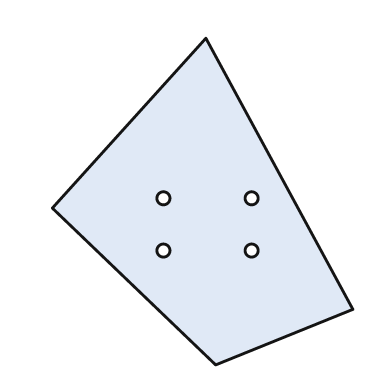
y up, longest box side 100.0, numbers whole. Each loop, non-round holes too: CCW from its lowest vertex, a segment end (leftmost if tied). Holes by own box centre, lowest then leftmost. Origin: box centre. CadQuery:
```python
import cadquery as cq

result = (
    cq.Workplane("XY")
    .moveTo(4.0, -50.0)
    .lineTo(46.0, -33.0)
    .lineTo(1.0, 50.0)
    .lineTo(-46.0, -2.0)
    .close()
    .moveTo(-12.0, -15.0)
    .circle(2.0)
    .moveTo(15.0, -15.0)
    .circle(2.0)
    .moveTo(-12.0, 1.0)
    .circle(2.0)
    .moveTo(15.0, 1.0)
    .circle(2.0)
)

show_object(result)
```